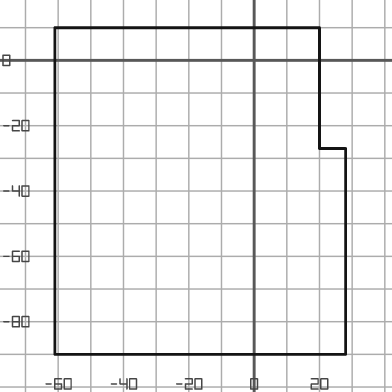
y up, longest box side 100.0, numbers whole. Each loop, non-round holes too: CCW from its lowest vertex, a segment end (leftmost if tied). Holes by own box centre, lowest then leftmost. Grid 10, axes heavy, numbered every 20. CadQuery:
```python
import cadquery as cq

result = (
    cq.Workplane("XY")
    .moveTo(-61.0, -90.0)
    .lineTo(28.0, -90.0)
    .lineTo(28.0, -27.0)
    .lineTo(20.0, -27.0)
    .lineTo(20.0, 10.0)
    .lineTo(-61.0, 10.0)
    .close()
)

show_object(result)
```